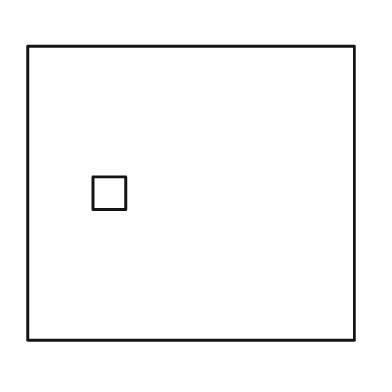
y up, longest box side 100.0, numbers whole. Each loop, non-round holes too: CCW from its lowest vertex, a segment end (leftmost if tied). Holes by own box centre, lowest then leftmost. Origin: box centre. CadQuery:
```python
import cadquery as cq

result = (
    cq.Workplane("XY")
    .moveTo(-50.0, -45.0)
    .lineTo(50.0, -45.0)
    .lineTo(50.0, 45.0)
    .lineTo(-50.0, 45.0)
    .close()
    .moveTo(-30.0, -5.0)
    .lineTo(-20.0, -5.0)
    .lineTo(-20.0, 5.0)
    .lineTo(-30.0, 5.0)
    .close()
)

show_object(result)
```